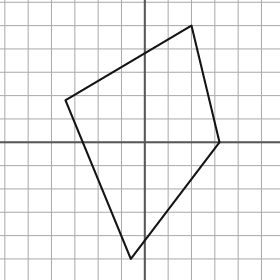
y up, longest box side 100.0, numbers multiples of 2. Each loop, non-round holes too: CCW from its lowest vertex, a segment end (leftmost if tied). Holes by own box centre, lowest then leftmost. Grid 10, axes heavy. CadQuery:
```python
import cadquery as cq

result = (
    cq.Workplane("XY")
    .moveTo(-6.0, -50.0)
    .lineTo(32.0, 0.0)
    .lineTo(20.0, 50.0)
    .lineTo(-34.0, 18.0)
    .close()
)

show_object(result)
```